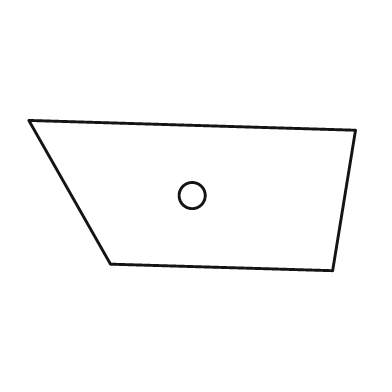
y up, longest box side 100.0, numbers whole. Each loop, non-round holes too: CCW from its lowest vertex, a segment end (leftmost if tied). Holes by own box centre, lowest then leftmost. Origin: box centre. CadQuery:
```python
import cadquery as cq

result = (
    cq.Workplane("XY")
    .moveTo(43.0, -23.0)
    .lineTo(50.0, 20.0)
    .lineTo(-50.0, 23.0)
    .lineTo(-25.0, -21.0)
    .close()
    .moveTo(0.0, 0.0)
    .circle(4.0)
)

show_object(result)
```